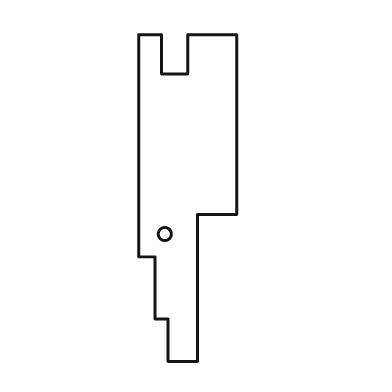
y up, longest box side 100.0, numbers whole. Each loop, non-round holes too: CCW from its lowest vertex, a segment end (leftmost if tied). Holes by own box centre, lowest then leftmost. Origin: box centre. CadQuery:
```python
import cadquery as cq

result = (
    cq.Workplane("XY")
    .moveTo(-6.0, -50.0)
    .lineTo(3.0, -50.0)
    .lineTo(3.0, -5.0)
    .lineTo(15.0, -5.0)
    .lineTo(15.0, 50.0)
    .lineTo(0.0, 50.0)
    .lineTo(0.0, 38.0)
    .lineTo(-8.0, 38.0)
    .lineTo(-8.0, 50.0)
    .lineTo(-15.0, 50.0)
    .lineTo(-15.0, -18.0)
    .lineTo(-10.0, -18.0)
    .lineTo(-10.0, -37.0)
    .lineTo(-6.0, -37.0)
    .close()
    .moveTo(-7.0, -11.0)
    .circle(2.0)
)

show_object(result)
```